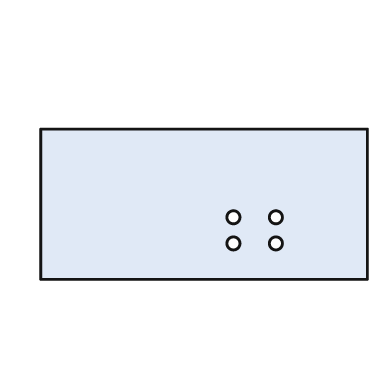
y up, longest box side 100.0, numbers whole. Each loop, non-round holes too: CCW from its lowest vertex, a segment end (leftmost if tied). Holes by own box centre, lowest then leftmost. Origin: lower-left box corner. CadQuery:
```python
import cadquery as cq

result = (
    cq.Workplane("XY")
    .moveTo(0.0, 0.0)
    .lineTo(100.0, 0.0)
    .lineTo(100.0, 46.0)
    .lineTo(0.0, 46.0)
    .close()
    .moveTo(59.0, 11.0)
    .circle(2.0)
    .moveTo(72.0, 11.0)
    .circle(2.0)
    .moveTo(59.0, 19.0)
    .circle(2.0)
    .moveTo(72.0, 19.0)
    .circle(2.0)
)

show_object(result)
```